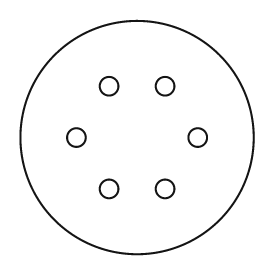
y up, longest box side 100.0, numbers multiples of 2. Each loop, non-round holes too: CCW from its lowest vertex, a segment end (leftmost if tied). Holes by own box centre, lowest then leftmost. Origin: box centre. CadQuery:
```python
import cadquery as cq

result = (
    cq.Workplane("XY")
    .moveTo(0.0, 0.0)
    .circle(50.0)
    .moveTo(-12.0, -22.0)
    .circle(4.0)
    .moveTo(12.0, -22.0)
    .circle(4.0)
    .moveTo(-26.0, 0.0)
    .circle(4.0)
    .moveTo(26.0, 0.0)
    .circle(4.0)
    .moveTo(-12.0, 22.0)
    .circle(4.0)
    .moveTo(12.0, 22.0)
    .circle(4.0)
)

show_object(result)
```